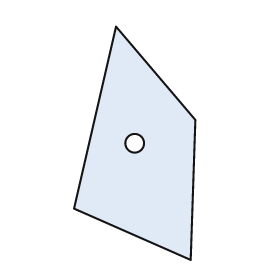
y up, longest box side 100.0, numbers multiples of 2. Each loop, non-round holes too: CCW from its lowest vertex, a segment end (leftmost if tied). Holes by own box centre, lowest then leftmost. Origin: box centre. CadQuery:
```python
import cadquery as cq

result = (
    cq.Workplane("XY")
    .moveTo(24.0, -50.0)
    .lineTo(26.0, 10.0)
    .lineTo(-8.0, 50.0)
    .lineTo(-26.0, -28.0)
    .close()
    .moveTo(0.0, 0.0)
    .circle(4.0)
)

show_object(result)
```